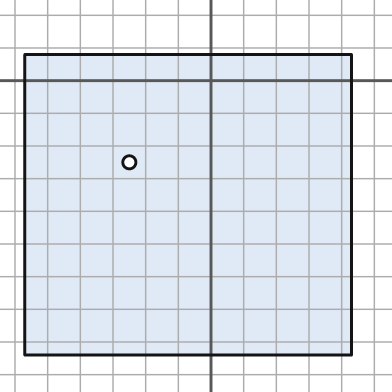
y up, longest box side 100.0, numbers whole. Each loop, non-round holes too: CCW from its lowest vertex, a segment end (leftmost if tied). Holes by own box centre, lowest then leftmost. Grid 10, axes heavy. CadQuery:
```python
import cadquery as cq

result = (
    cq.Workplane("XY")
    .moveTo(-57.0, -84.0)
    .lineTo(43.0, -84.0)
    .lineTo(43.0, 8.0)
    .lineTo(-57.0, 8.0)
    .close()
    .moveTo(-25.0, -25.0)
    .circle(2.0)
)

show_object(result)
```